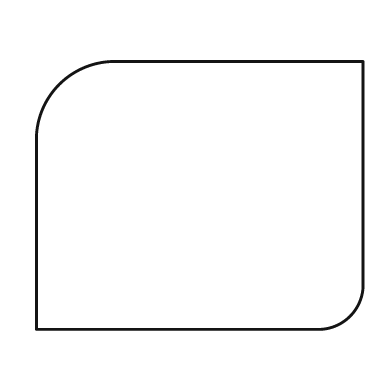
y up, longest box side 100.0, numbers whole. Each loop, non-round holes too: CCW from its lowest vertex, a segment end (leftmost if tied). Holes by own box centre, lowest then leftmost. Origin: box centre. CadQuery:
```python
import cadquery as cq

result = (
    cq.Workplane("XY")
    .moveTo(-50.0, -41.0)
    .lineTo(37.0, -41.0)
    .threePointArc((46.0, -37.0), (50.0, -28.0))
    .lineTo(50.0, 41.0)
    .lineTo(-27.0, 41.0)
    .threePointArc((-43.0, 34.0), (-50.0, 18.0))
    .close()
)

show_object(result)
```